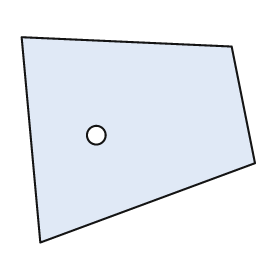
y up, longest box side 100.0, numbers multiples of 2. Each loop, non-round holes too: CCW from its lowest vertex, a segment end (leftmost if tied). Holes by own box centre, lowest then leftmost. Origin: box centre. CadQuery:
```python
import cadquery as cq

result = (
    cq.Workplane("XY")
    .moveTo(-42.0, -44.0)
    .lineTo(50.0, -10.0)
    .lineTo(40.0, 40.0)
    .lineTo(-50.0, 44.0)
    .close()
    .moveTo(-18.0, 2.0)
    .circle(4.0)
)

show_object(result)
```